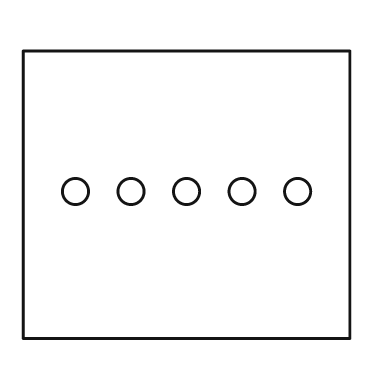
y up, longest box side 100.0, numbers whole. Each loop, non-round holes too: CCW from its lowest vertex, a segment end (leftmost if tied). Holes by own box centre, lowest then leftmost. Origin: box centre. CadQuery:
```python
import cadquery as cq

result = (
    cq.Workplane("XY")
    .moveTo(-50.0, -44.0)
    .lineTo(50.0, -44.0)
    .lineTo(50.0, 44.0)
    .lineTo(-50.0, 44.0)
    .close()
    .moveTo(-34.0, 1.0)
    .circle(4.0)
    .moveTo(-17.0, 1.0)
    .circle(4.0)
    .moveTo(0.0, 1.0)
    .circle(4.0)
    .moveTo(17.0, 1.0)
    .circle(4.0)
    .moveTo(34.0, 1.0)
    .circle(4.0)
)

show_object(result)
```